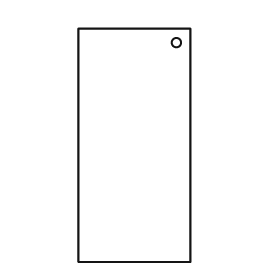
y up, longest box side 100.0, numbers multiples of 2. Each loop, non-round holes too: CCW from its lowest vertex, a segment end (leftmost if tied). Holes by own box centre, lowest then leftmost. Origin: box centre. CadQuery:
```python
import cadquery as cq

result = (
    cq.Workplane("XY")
    .moveTo(-24.0, -50.0)
    .lineTo(24.0, -50.0)
    .lineTo(24.0, 50.0)
    .lineTo(-24.0, 50.0)
    .close()
    .moveTo(18.0, 44.0)
    .circle(2.0)
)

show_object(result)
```